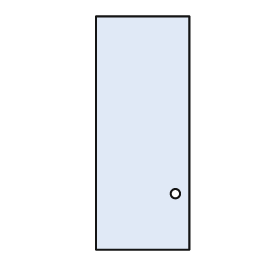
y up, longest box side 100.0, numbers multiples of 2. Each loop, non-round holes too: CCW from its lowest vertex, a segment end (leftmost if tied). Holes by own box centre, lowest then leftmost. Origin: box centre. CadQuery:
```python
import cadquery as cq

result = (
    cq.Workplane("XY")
    .moveTo(-20.0, -50.0)
    .lineTo(20.0, -50.0)
    .lineTo(20.0, 50.0)
    .lineTo(-20.0, 50.0)
    .close()
    .moveTo(14.0, -26.0)
    .circle(2.0)
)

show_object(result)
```